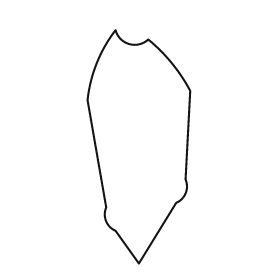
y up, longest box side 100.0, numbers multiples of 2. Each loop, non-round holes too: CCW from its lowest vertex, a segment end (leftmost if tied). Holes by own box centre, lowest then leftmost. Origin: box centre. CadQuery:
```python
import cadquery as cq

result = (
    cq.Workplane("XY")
    .moveTo(0.0, -50.0)
    .lineTo(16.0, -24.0)
    .threePointArc((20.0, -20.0), (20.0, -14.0))
    .lineTo(22.0, 24.0)
    .threePointArc((14.0, 36.0), (4.0, 46.0))
    .threePointArc((-4.0, 44.0), (-10.0, 50.0))
    .threePointArc((-18.0, 36.0), (-22.0, 20.0))
    .lineTo(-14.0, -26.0)
    .threePointArc((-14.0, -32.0), (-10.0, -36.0))
    .close()
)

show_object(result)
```